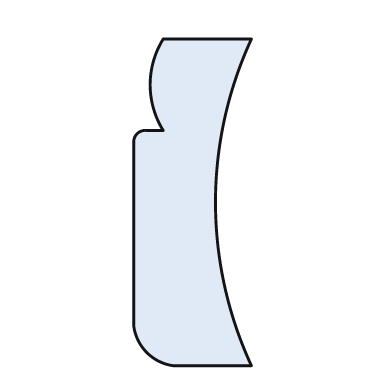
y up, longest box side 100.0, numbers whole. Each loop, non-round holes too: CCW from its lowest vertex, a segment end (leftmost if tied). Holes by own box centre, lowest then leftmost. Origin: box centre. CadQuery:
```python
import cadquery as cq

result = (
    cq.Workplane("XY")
    .moveTo(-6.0, -50.0)
    .lineTo(18.0, -50.0)
    .threePointArc((7.0, 0.0), (18.0, 50.0))
    .lineTo(-9.0, 50.0)
    .threePointArc((-13.0, 36.0), (-9.0, 22.0))
    .lineTo(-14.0, 22.0)
    .threePointArc((-17.0, 21.0), (-18.0, 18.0))
    .lineTo(-18.0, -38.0)
    .threePointArc((-14.0, -46.0), (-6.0, -50.0))
    .close()
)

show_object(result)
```